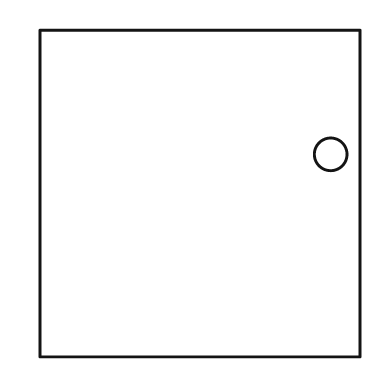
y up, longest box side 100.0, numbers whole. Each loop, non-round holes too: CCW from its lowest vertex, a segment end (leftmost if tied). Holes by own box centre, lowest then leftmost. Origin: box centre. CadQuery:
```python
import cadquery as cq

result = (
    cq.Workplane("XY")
    .moveTo(-49.0, -50.0)
    .lineTo(49.0, -50.0)
    .lineTo(49.0, 50.0)
    .lineTo(-49.0, 50.0)
    .close()
    .moveTo(40.0, 12.0)
    .circle(5.0)
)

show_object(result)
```